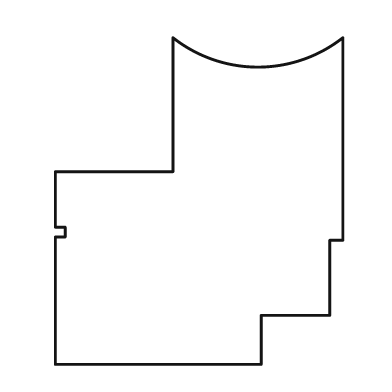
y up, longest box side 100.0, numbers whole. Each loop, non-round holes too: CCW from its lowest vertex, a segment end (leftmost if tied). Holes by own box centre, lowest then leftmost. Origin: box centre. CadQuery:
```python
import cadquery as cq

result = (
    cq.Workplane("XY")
    .moveTo(-44.0, -50.0)
    .lineTo(19.0, -50.0)
    .lineTo(19.0, -35.0)
    .lineTo(40.0, -35.0)
    .lineTo(40.0, -12.0)
    .lineTo(44.0, -12.0)
    .lineTo(44.0, 50.0)
    .threePointArc((18.0, 41.0), (-8.0, 50.0))
    .lineTo(-8.0, 9.0)
    .lineTo(-44.0, 9.0)
    .lineTo(-44.0, -8.0)
    .lineTo(-41.0, -8.0)
    .lineTo(-41.0, -11.0)
    .lineTo(-44.0, -11.0)
    .close()
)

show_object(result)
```